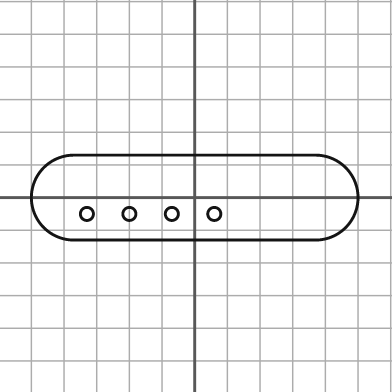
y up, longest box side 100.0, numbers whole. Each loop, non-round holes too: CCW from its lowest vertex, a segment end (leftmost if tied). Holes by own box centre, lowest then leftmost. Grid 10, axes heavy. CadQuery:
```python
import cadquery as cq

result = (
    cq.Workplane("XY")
    .moveTo(-37.0, -13.0)
    .lineTo(37.0, -13.0)
    .threePointArc((50.0, 0.0), (37.0, 13.0))
    .lineTo(-37.0, 13.0)
    .threePointArc((-50.0, 0.0), (-37.0, -13.0))
    .close()
    .moveTo(-33.0, -5.0)
    .circle(2.0)
    .moveTo(-20.0, -5.0)
    .circle(2.0)
    .moveTo(-7.0, -5.0)
    .circle(2.0)
    .moveTo(6.0, -5.0)
    .circle(2.0)
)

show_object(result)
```